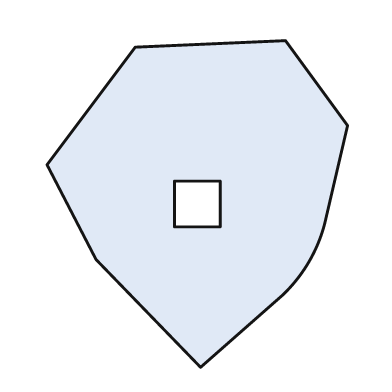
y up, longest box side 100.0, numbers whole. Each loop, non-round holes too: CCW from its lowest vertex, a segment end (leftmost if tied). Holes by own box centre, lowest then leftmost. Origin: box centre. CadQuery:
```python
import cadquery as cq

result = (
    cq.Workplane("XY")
    .moveTo(1.0, -50.0)
    .lineTo(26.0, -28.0)
    .threePointArc((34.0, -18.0), (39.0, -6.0))
    .lineTo(46.0, 24.0)
    .lineTo(27.0, 50.0)
    .lineTo(-19.0, 48.0)
    .lineTo(-46.0, 12.0)
    .lineTo(-31.0, -17.0)
    .close()
    .moveTo(-7.0, -7.0)
    .lineTo(7.0, -7.0)
    .lineTo(7.0, 7.0)
    .lineTo(-7.0, 7.0)
    .close()
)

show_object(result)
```